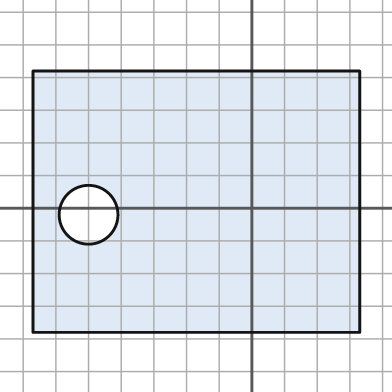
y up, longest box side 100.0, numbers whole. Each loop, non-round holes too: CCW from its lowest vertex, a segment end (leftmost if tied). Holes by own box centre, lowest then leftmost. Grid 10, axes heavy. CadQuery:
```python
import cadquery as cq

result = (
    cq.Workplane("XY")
    .moveTo(-67.0, -38.0)
    .lineTo(33.0, -38.0)
    .lineTo(33.0, 42.0)
    .lineTo(-67.0, 42.0)
    .close()
    .moveTo(-50.0, -2.0)
    .circle(9.0)
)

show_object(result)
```